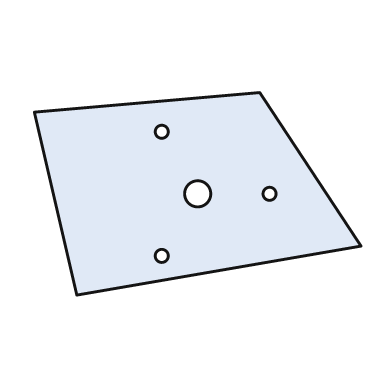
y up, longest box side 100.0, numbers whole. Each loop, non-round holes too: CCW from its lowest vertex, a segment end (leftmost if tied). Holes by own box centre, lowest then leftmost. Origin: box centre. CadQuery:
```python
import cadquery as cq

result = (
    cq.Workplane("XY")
    .moveTo(-37.0, -31.0)
    .lineTo(50.0, -16.0)
    .lineTo(19.0, 31.0)
    .lineTo(-50.0, 25.0)
    .close()
    .moveTo(-11.0, -19.0)
    .circle(2.0)
    .moveTo(0.0, 0.0)
    .circle(4.0)
    .moveTo(22.0, 0.0)
    .circle(2.0)
    .moveTo(-11.0, 19.0)
    .circle(2.0)
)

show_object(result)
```